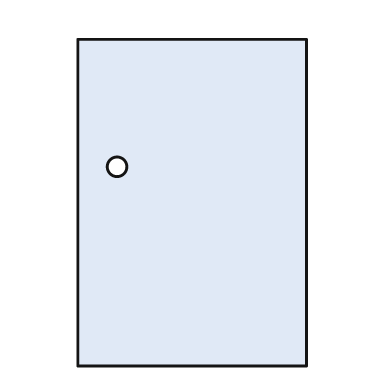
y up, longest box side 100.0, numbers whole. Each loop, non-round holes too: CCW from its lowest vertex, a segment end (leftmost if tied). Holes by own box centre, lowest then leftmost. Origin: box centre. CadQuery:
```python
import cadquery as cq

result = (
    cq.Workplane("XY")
    .moveTo(-35.0, -50.0)
    .lineTo(35.0, -50.0)
    .lineTo(35.0, 50.0)
    .lineTo(-35.0, 50.0)
    .close()
    .moveTo(-23.0, 11.0)
    .circle(3.0)
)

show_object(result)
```